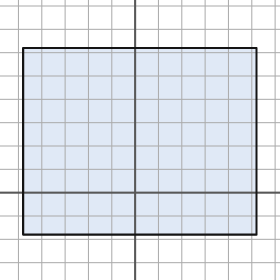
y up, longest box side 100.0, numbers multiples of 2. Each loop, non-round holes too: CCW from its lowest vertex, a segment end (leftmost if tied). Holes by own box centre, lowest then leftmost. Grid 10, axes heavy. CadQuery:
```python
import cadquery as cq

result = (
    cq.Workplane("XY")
    .moveTo(-48.0, -18.0)
    .lineTo(52.0, -18.0)
    .lineTo(52.0, 62.0)
    .lineTo(-48.0, 62.0)
    .close()
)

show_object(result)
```